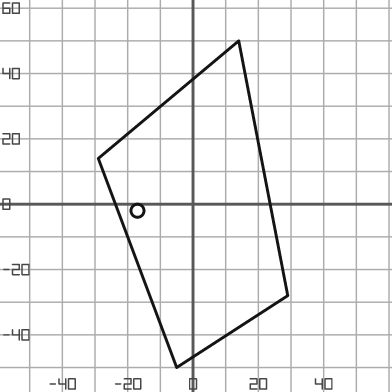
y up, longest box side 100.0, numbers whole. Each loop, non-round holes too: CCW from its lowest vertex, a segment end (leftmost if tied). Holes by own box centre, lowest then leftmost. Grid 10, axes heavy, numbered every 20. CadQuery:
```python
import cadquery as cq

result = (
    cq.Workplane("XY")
    .moveTo(-5.0, -50.0)
    .lineTo(29.0, -28.0)
    .lineTo(14.0, 50.0)
    .lineTo(-29.0, 14.0)
    .close()
    .moveTo(-17.0, -2.0)
    .circle(2.0)
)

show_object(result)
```